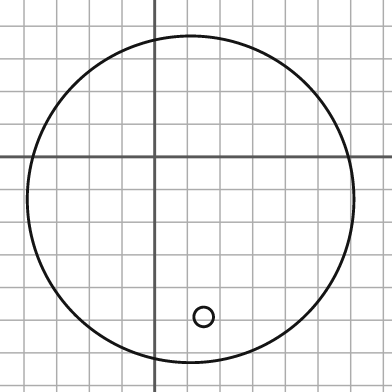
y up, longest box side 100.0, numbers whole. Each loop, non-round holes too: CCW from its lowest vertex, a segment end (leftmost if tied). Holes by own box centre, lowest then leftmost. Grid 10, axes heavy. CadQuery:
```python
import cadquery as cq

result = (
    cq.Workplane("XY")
    .moveTo(11.0, -13.0)
    .circle(50.0)
    .moveTo(15.0, -49.0)
    .circle(3.0)
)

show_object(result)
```